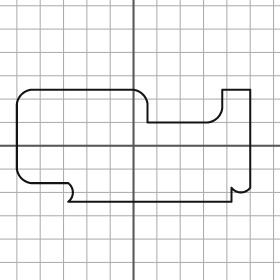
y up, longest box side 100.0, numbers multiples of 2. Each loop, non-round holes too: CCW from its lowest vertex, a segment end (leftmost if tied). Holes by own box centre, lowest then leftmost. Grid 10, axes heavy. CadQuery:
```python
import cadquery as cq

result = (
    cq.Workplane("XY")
    .moveTo(-28.0, -24.0)
    .lineTo(42.0, -24.0)
    .lineTo(42.0, -18.0)
    .threePointArc((46.0, -20.0), (50.0, -18.0))
    .lineTo(50.0, 24.0)
    .lineTo(38.0, 24.0)
    .lineTo(38.0, 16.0)
    .threePointArc((36.0, 12.0), (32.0, 10.0))
    .lineTo(6.0, 10.0)
    .lineTo(6.0, 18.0)
    .threePointArc((4.0, 22.0), (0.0, 24.0))
    .lineTo(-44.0, 24.0)
    .threePointArc((-48.0, 22.0), (-50.0, 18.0))
    .lineTo(-50.0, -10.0)
    .threePointArc((-48.0, -14.0), (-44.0, -16.0))
    .lineTo(-28.0, -16.0)
    .threePointArc((-26.0, -20.0), (-28.0, -24.0))
    .close()
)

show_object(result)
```